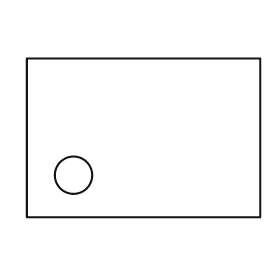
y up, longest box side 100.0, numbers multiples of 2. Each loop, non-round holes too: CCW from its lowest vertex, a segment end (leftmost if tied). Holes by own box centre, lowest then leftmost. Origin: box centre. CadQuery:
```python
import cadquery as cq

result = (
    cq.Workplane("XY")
    .moveTo(-50.0, -34.0)
    .lineTo(50.0, -34.0)
    .lineTo(50.0, 34.0)
    .lineTo(-50.0, 34.0)
    .close()
    .moveTo(-30.0, -16.0)
    .circle(8.0)
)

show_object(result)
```